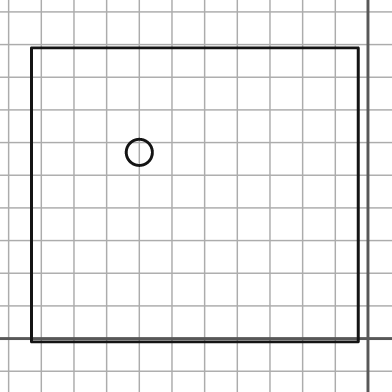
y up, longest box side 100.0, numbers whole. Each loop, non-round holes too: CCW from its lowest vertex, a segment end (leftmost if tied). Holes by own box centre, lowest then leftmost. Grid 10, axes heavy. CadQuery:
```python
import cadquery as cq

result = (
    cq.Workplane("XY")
    .moveTo(-103.0, -1.0)
    .lineTo(-3.0, -1.0)
    .lineTo(-3.0, 89.0)
    .lineTo(-103.0, 89.0)
    .close()
    .moveTo(-70.0, 57.0)
    .circle(4.0)
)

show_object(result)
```